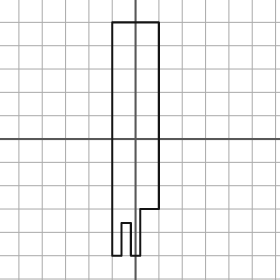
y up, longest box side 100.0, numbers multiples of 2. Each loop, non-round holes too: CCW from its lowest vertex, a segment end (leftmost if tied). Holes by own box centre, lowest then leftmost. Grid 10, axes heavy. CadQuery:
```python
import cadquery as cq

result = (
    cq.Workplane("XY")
    .moveTo(-10.0, -50.0)
    .lineTo(-6.0, -50.0)
    .lineTo(-6.0, -36.0)
    .lineTo(-2.0, -36.0)
    .lineTo(-2.0, -50.0)
    .lineTo(2.0, -50.0)
    .lineTo(2.0, -30.0)
    .lineTo(10.0, -30.0)
    .lineTo(10.0, 50.0)
    .lineTo(-10.0, 50.0)
    .close()
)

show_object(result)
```